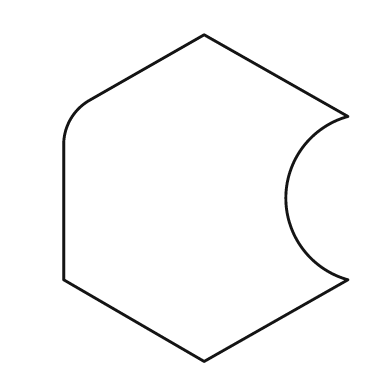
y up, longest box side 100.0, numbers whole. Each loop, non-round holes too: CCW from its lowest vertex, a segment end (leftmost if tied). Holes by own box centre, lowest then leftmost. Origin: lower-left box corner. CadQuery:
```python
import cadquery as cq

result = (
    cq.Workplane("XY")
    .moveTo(43.0, 0.0)
    .lineTo(87.0, 25.0)
    .threePointArc((68.0, 50.0), (87.0, 75.0))
    .lineTo(43.0, 100.0)
    .lineTo(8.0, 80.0)
    .threePointArc((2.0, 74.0), (0.0, 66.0))
    .lineTo(0.0, 25.0)
    .close()
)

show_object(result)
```